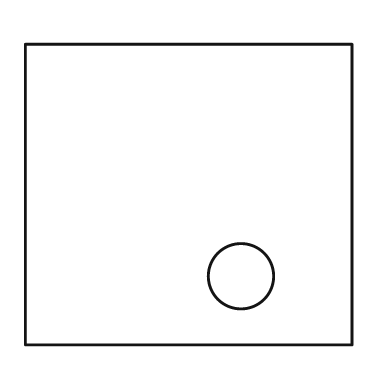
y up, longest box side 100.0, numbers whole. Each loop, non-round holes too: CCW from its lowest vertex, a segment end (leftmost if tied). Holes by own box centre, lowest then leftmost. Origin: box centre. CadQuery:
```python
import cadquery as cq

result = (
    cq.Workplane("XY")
    .moveTo(-50.0, -46.0)
    .lineTo(50.0, -46.0)
    .lineTo(50.0, 46.0)
    .lineTo(-50.0, 46.0)
    .close()
    .moveTo(16.0, -25.0)
    .circle(10.0)
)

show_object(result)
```